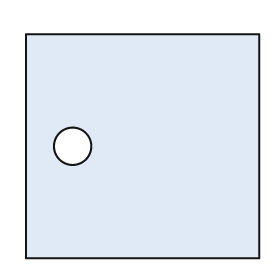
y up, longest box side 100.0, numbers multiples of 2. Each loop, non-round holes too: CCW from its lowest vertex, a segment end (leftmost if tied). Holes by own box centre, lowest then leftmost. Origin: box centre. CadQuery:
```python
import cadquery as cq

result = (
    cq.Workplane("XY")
    .moveTo(-50.0, -48.0)
    .lineTo(50.0, -48.0)
    .lineTo(50.0, 48.0)
    .lineTo(-50.0, 48.0)
    .close()
    .moveTo(-30.0, 0.0)
    .circle(8.0)
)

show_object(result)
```